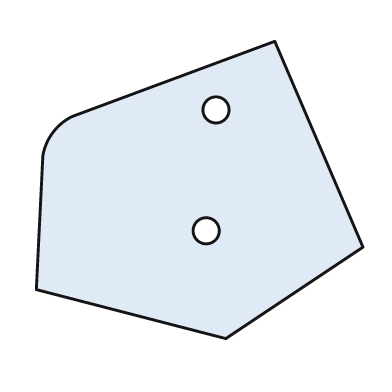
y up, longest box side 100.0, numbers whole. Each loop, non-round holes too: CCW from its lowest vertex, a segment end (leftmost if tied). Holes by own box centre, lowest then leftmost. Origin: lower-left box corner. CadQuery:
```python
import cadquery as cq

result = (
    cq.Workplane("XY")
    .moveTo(58.0, 0.0)
    .lineTo(100.0, 28.0)
    .lineTo(73.0, 91.0)
    .lineTo(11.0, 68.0)
    .threePointArc((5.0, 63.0), (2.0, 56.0))
    .lineTo(0.0, 15.0)
    .close()
    .moveTo(52.0, 33.0)
    .circle(4.0)
    .moveTo(55.0, 70.0)
    .circle(4.0)
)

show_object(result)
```